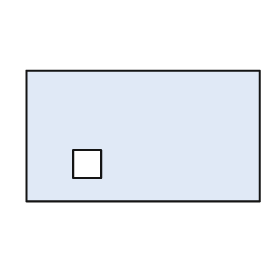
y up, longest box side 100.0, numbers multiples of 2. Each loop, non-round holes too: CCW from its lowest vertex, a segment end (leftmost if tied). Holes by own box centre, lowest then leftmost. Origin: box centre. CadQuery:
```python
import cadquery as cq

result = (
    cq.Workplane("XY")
    .moveTo(-50.0, -28.0)
    .lineTo(50.0, -28.0)
    .lineTo(50.0, 28.0)
    .lineTo(-50.0, 28.0)
    .close()
    .moveTo(-30.0, -18.0)
    .lineTo(-18.0, -18.0)
    .lineTo(-18.0, -6.0)
    .lineTo(-30.0, -6.0)
    .close()
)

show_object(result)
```